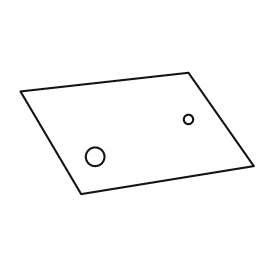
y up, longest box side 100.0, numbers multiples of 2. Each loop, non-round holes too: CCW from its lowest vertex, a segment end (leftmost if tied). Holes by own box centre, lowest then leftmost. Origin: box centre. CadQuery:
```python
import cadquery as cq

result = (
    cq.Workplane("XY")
    .moveTo(-24.0, -26.0)
    .lineTo(50.0, -14.0)
    .lineTo(22.0, 26.0)
    .lineTo(-50.0, 18.0)
    .close()
    .moveTo(-18.0, -10.0)
    .circle(4.0)
    .moveTo(22.0, 6.0)
    .circle(2.0)
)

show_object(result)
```